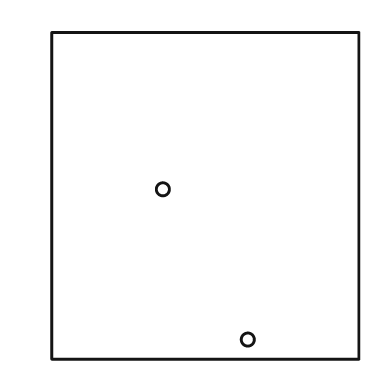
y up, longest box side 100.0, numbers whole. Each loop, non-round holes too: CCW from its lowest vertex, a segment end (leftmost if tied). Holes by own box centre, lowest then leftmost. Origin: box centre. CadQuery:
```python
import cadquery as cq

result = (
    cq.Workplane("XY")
    .moveTo(-47.0, -50.0)
    .lineTo(47.0, -50.0)
    .lineTo(47.0, 50.0)
    .lineTo(-47.0, 50.0)
    .close()
    .moveTo(13.0, -44.0)
    .circle(2.0)
    .moveTo(-13.0, 2.0)
    .circle(2.0)
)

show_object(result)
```